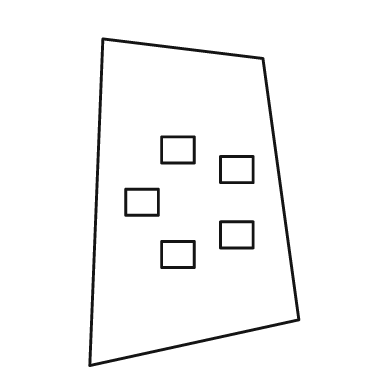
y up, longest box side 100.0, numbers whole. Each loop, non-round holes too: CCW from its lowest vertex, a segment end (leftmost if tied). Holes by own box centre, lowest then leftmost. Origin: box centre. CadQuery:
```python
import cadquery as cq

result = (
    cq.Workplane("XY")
    .moveTo(-32.0, -50.0)
    .lineTo(32.0, -36.0)
    .lineTo(21.0, 44.0)
    .lineTo(-28.0, 50.0)
    .close()
    .moveTo(-10.0, -20.0)
    .lineTo(0.0, -20.0)
    .lineTo(0.0, -12.0)
    .lineTo(-10.0, -12.0)
    .close()
    .moveTo(8.0, -14.0)
    .lineTo(18.0, -14.0)
    .lineTo(18.0, -6.0)
    .lineTo(8.0, -6.0)
    .close()
    .moveTo(-21.0, -4.0)
    .lineTo(-11.0, -4.0)
    .lineTo(-11.0, 4.0)
    .lineTo(-21.0, 4.0)
    .close()
    .moveTo(8.0, 6.0)
    .lineTo(18.0, 6.0)
    .lineTo(18.0, 14.0)
    .lineTo(8.0, 14.0)
    .close()
    .moveTo(-10.0, 12.0)
    .lineTo(0.0, 12.0)
    .lineTo(0.0, 20.0)
    .lineTo(-10.0, 20.0)
    .close()
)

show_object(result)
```